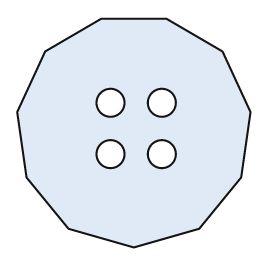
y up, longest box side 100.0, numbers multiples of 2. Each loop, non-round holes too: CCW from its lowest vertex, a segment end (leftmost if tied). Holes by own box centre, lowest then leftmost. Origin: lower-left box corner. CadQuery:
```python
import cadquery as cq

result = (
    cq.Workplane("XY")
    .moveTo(50.0, 0.0)
    .lineTo(78.0, 8.0)
    .lineTo(96.0, 30.0)
    .lineTo(100.0, 58.0)
    .lineTo(88.0, 84.0)
    .lineTo(64.0, 98.0)
    .lineTo(36.0, 98.0)
    .lineTo(12.0, 84.0)
    .lineTo(0.0, 58.0)
    .lineTo(4.0, 30.0)
    .lineTo(22.0, 8.0)
    .close()
    .moveTo(40.0, 40.0)
    .circle(6.0)
    .moveTo(62.0, 40.0)
    .circle(6.0)
    .moveTo(40.0, 62.0)
    .circle(6.0)
    .moveTo(62.0, 62.0)
    .circle(6.0)
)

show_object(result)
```